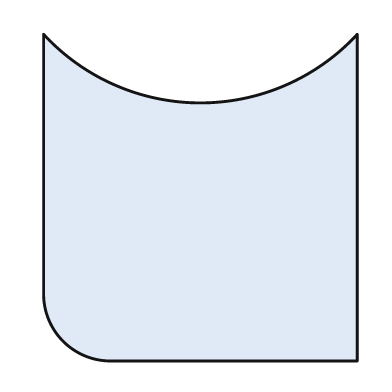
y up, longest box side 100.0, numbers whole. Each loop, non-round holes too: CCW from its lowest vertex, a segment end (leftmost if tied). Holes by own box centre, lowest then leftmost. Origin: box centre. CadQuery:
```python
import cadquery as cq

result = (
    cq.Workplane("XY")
    .moveTo(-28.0, -50.0)
    .lineTo(48.0, -50.0)
    .lineTo(48.0, 50.0)
    .threePointArc((0.0, 29.0), (-48.0, 50.0))
    .lineTo(-48.0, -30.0)
    .threePointArc((-42.0, -44.0), (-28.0, -50.0))
    .close()
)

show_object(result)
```